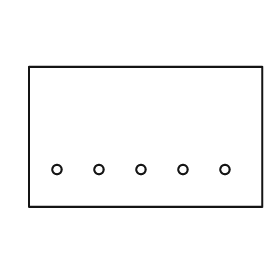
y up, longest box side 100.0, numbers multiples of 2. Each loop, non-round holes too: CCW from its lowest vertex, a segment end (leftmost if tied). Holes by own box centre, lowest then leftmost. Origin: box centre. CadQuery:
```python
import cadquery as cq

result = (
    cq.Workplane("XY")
    .moveTo(-50.0, -30.0)
    .lineTo(50.0, -30.0)
    .lineTo(50.0, 30.0)
    .lineTo(-50.0, 30.0)
    .close()
    .moveTo(-38.0, -14.0)
    .circle(2.0)
    .moveTo(-20.0, -14.0)
    .circle(2.0)
    .moveTo(-2.0, -14.0)
    .circle(2.0)
    .moveTo(16.0, -14.0)
    .circle(2.0)
    .moveTo(34.0, -14.0)
    .circle(2.0)
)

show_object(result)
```